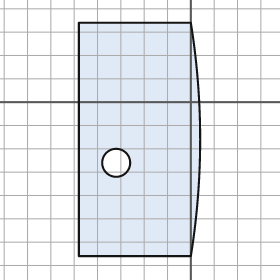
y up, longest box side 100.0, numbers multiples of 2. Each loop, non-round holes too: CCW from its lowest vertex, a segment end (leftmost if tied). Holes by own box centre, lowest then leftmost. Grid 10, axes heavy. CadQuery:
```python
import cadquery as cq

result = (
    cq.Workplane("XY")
    .moveTo(-48.0, -66.0)
    .lineTo(0.0, -66.0)
    .threePointArc((4.0, -16.0), (0.0, 34.0))
    .lineTo(-48.0, 34.0)
    .close()
    .moveTo(-32.0, -26.0)
    .circle(6.0)
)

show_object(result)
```